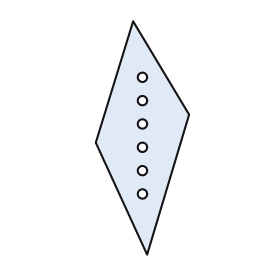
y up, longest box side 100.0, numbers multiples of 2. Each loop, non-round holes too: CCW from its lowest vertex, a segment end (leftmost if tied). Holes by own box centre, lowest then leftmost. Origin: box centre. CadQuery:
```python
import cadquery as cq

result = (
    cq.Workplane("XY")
    .moveTo(2.0, -50.0)
    .lineTo(20.0, 10.0)
    .lineTo(-4.0, 50.0)
    .lineTo(-20.0, -2.0)
    .close()
    .moveTo(0.0, -24.0)
    .circle(2.0)
    .moveTo(0.0, -14.0)
    .circle(2.0)
    .moveTo(0.0, -4.0)
    .circle(2.0)
    .moveTo(0.0, 6.0)
    .circle(2.0)
    .moveTo(0.0, 16.0)
    .circle(2.0)
    .moveTo(0.0, 26.0)
    .circle(2.0)
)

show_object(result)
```